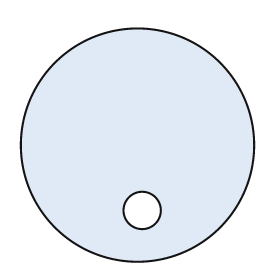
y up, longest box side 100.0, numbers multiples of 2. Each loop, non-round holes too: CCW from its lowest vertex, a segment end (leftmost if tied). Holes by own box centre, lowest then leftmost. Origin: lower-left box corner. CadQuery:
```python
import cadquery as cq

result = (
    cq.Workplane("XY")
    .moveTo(50.0, 50.0)
    .circle(50.0)
    .moveTo(52.0, 22.0)
    .circle(8.0)
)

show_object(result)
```